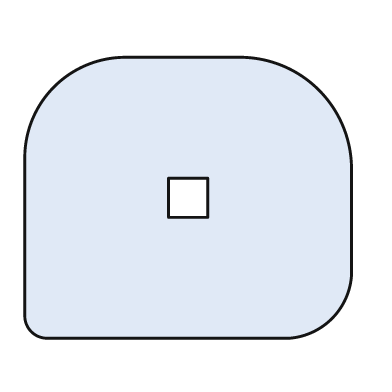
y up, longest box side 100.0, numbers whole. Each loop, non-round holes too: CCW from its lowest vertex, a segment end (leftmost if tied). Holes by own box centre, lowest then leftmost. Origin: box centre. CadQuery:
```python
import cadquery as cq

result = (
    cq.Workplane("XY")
    .moveTo(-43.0, -43.0)
    .lineTo(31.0, -43.0)
    .threePointArc((44.0, -37.0), (50.0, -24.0))
    .lineTo(50.0, 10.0)
    .threePointArc((40.0, 33.0), (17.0, 43.0))
    .lineTo(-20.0, 43.0)
    .threePointArc((-41.0, 34.0), (-50.0, 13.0))
    .lineTo(-50.0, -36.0)
    .threePointArc((-48.0, -41.0), (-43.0, -43.0))
    .close()
    .moveTo(-6.0, -6.0)
    .lineTo(6.0, -6.0)
    .lineTo(6.0, 6.0)
    .lineTo(-6.0, 6.0)
    .close()
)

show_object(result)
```